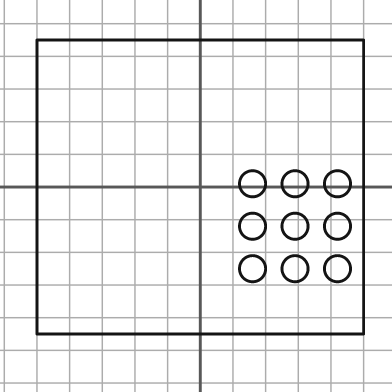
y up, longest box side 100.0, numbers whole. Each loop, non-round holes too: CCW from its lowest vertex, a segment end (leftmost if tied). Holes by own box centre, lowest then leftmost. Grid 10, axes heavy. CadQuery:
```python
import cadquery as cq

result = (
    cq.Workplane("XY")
    .moveTo(-50.0, -45.0)
    .lineTo(50.0, -45.0)
    .lineTo(50.0, 45.0)
    .lineTo(-50.0, 45.0)
    .close()
    .moveTo(16.0, -25.0)
    .circle(4.0)
    .moveTo(29.0, -25.0)
    .circle(4.0)
    .moveTo(42.0, -25.0)
    .circle(4.0)
    .moveTo(16.0, -12.0)
    .circle(4.0)
    .moveTo(29.0, -12.0)
    .circle(4.0)
    .moveTo(42.0, -12.0)
    .circle(4.0)
    .moveTo(16.0, 1.0)
    .circle(4.0)
    .moveTo(29.0, 1.0)
    .circle(4.0)
    .moveTo(42.0, 1.0)
    .circle(4.0)
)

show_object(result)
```